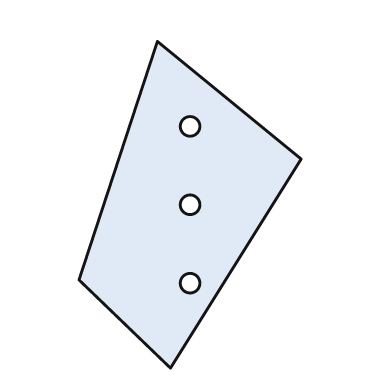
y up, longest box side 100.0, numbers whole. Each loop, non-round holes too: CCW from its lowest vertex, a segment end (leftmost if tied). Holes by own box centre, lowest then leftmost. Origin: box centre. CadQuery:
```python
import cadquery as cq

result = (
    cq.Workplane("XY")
    .moveTo(-6.0, -50.0)
    .lineTo(34.0, 14.0)
    .lineTo(-10.0, 50.0)
    .lineTo(-34.0, -23.0)
    .close()
    .moveTo(0.0, -24.0)
    .circle(3.0)
    .moveTo(0.0, 0.0)
    .circle(3.0)
    .moveTo(0.0, 24.0)
    .circle(3.0)
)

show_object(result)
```